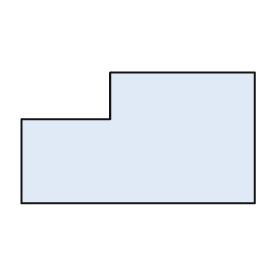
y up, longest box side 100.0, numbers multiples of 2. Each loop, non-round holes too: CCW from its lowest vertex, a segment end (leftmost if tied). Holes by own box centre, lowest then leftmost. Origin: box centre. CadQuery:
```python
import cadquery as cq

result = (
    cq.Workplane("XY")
    .moveTo(-50.0, -28.0)
    .lineTo(50.0, -28.0)
    .lineTo(50.0, 28.0)
    .lineTo(-12.0, 28.0)
    .lineTo(-12.0, 8.0)
    .lineTo(-50.0, 8.0)
    .close()
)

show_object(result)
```